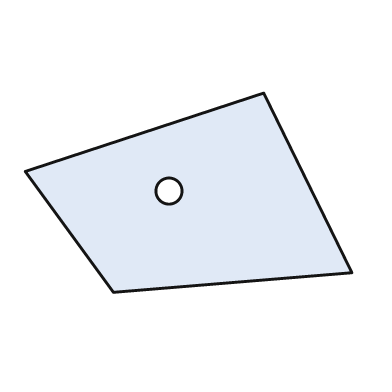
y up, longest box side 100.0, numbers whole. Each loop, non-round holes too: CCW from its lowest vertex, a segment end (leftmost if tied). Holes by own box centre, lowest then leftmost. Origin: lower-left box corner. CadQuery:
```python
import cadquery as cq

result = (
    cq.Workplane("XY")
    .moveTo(27.0, 0.0)
    .lineTo(100.0, 6.0)
    .lineTo(73.0, 61.0)
    .lineTo(0.0, 37.0)
    .close()
    .moveTo(44.0, 31.0)
    .circle(4.0)
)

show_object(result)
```